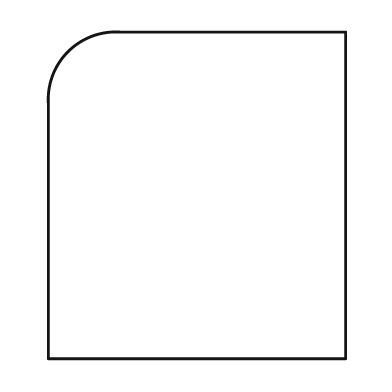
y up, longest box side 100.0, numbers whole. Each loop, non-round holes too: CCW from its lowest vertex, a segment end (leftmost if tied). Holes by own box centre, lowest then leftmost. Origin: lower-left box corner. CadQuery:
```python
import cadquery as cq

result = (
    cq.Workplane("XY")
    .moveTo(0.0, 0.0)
    .lineTo(91.0, 0.0)
    .lineTo(91.0, 100.0)
    .lineTo(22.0, 100.0)
    .threePointArc((6.0, 94.0), (0.0, 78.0))
    .close()
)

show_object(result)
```